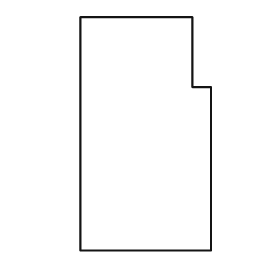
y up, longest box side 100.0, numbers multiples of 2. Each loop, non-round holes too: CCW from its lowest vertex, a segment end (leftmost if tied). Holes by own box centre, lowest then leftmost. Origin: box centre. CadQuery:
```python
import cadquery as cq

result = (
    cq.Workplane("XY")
    .moveTo(-28.0, -50.0)
    .lineTo(28.0, -50.0)
    .lineTo(28.0, 20.0)
    .lineTo(20.0, 20.0)
    .lineTo(20.0, 50.0)
    .lineTo(-28.0, 50.0)
    .close()
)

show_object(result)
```